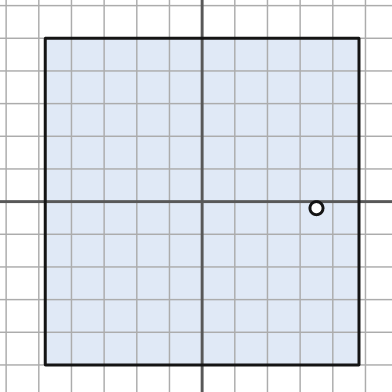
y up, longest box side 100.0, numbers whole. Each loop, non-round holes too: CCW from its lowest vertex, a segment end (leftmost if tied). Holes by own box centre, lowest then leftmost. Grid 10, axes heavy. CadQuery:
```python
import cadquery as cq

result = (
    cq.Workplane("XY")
    .moveTo(-48.0, -50.0)
    .lineTo(48.0, -50.0)
    .lineTo(48.0, 50.0)
    .lineTo(-48.0, 50.0)
    .close()
    .moveTo(35.0, -2.0)
    .circle(2.0)
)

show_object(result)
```